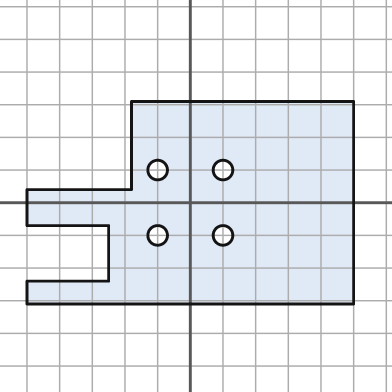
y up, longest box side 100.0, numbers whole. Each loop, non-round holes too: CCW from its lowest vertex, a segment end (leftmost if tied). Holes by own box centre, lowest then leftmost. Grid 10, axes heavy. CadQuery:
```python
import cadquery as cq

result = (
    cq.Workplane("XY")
    .moveTo(-50.0, -31.0)
    .lineTo(50.0, -31.0)
    .lineTo(50.0, 31.0)
    .lineTo(-18.0, 31.0)
    .lineTo(-18.0, 4.0)
    .lineTo(-50.0, 4.0)
    .lineTo(-50.0, -7.0)
    .lineTo(-25.0, -7.0)
    .lineTo(-25.0, -24.0)
    .lineTo(-50.0, -24.0)
    .close()
    .moveTo(-10.0, -10.0)
    .circle(3.0)
    .moveTo(10.0, -10.0)
    .circle(3.0)
    .moveTo(-10.0, 10.0)
    .circle(3.0)
    .moveTo(10.0, 10.0)
    .circle(3.0)
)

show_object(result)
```